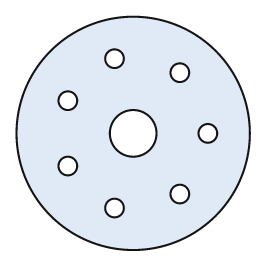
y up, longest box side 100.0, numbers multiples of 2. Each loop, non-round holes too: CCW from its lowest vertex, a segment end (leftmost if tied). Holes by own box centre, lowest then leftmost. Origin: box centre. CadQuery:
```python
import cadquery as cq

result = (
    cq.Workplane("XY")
    .moveTo(0.0, 0.0)
    .circle(50.0)
    .moveTo(-8.0, -32.0)
    .circle(4.0)
    .moveTo(20.0, -26.0)
    .circle(4.0)
    .moveTo(-28.0, -14.0)
    .circle(4.0)
    .moveTo(0.0, 0.0)
    .circle(10.0)
    .moveTo(32.0, 0.0)
    .circle(4.0)
    .moveTo(-28.0, 14.0)
    .circle(4.0)
    .moveTo(20.0, 26.0)
    .circle(4.0)
    .moveTo(-8.0, 32.0)
    .circle(4.0)
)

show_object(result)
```